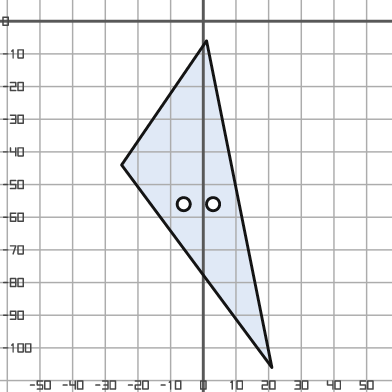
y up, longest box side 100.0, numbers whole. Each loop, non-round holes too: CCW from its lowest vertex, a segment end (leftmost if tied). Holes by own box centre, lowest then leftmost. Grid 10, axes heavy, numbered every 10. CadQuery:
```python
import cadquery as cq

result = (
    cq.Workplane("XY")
    .moveTo(21.0, -106.0)
    .lineTo(1.0, -6.0)
    .lineTo(-25.0, -44.0)
    .close()
    .moveTo(-6.0, -56.0)
    .circle(2.0)
    .moveTo(3.0, -56.0)
    .circle(2.0)
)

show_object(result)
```